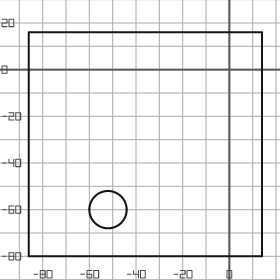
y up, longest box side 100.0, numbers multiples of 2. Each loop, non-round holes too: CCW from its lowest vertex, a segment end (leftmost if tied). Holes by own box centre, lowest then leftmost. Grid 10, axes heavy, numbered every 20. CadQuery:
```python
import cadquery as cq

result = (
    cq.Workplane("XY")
    .moveTo(-86.0, -80.0)
    .lineTo(14.0, -80.0)
    .lineTo(14.0, 16.0)
    .lineTo(-86.0, 16.0)
    .close()
    .moveTo(-52.0, -60.0)
    .circle(8.0)
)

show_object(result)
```